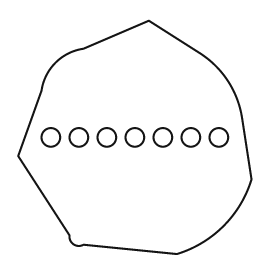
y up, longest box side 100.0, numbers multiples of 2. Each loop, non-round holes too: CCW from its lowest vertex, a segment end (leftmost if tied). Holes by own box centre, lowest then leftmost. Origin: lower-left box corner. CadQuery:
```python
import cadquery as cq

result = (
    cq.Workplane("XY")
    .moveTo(68.0, 0.0)
    .threePointArc((88.0, 12.0), (100.0, 32.0))
    .lineTo(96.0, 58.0)
    .threePointArc((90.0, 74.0), (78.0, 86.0))
    .lineTo(56.0, 100.0)
    .lineTo(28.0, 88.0)
    .threePointArc((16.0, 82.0), (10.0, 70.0))
    .lineTo(0.0, 42.0)
    .lineTo(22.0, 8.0)
    .threePointArc((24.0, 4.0), (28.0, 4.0))
    .close()
    .moveTo(14.0, 50.0)
    .circle(4.0)
    .moveTo(26.0, 50.0)
    .circle(4.0)
    .moveTo(38.0, 50.0)
    .circle(4.0)
    .moveTo(50.0, 50.0)
    .circle(4.0)
    .moveTo(62.0, 50.0)
    .circle(4.0)
    .moveTo(74.0, 50.0)
    .circle(4.0)
    .moveTo(86.0, 50.0)
    .circle(4.0)
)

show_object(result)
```